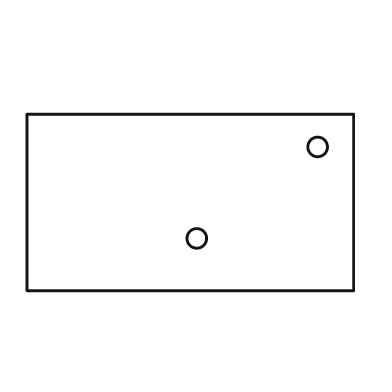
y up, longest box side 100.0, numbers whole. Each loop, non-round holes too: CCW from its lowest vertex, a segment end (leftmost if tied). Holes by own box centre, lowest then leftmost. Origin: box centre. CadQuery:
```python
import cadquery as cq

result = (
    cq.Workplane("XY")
    .moveTo(-50.0, -27.0)
    .lineTo(50.0, -27.0)
    .lineTo(50.0, 27.0)
    .lineTo(-50.0, 27.0)
    .close()
    .moveTo(2.0, -11.0)
    .circle(3.0)
    .moveTo(39.0, 17.0)
    .circle(3.0)
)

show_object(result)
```